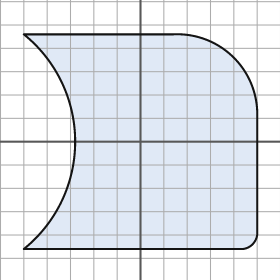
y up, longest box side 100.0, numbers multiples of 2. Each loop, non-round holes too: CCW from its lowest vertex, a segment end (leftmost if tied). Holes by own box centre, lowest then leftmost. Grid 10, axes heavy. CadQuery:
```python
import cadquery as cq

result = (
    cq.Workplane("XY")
    .moveTo(-50.0, -46.0)
    .lineTo(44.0, -46.0)
    .threePointArc((48.0, -44.0), (50.0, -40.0))
    .lineTo(50.0, 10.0)
    .threePointArc((40.0, 36.0), (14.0, 46.0))
    .lineTo(-50.0, 46.0)
    .threePointArc((-28.0, 0.0), (-50.0, -46.0))
    .close()
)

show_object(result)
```